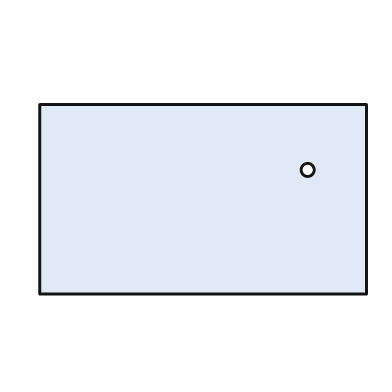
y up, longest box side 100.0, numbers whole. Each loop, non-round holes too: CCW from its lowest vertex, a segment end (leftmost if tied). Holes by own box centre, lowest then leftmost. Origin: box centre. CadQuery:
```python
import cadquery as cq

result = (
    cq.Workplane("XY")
    .moveTo(-50.0, -29.0)
    .lineTo(50.0, -29.0)
    .lineTo(50.0, 29.0)
    .lineTo(-50.0, 29.0)
    .close()
    .moveTo(32.0, 9.0)
    .circle(2.0)
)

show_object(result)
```